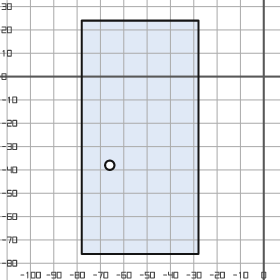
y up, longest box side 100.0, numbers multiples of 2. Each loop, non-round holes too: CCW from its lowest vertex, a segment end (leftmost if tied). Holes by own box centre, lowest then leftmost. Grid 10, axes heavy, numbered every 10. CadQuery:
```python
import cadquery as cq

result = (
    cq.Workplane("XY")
    .moveTo(-78.0, -76.0)
    .lineTo(-28.0, -76.0)
    .lineTo(-28.0, 24.0)
    .lineTo(-78.0, 24.0)
    .close()
    .moveTo(-66.0, -38.0)
    .circle(2.0)
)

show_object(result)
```